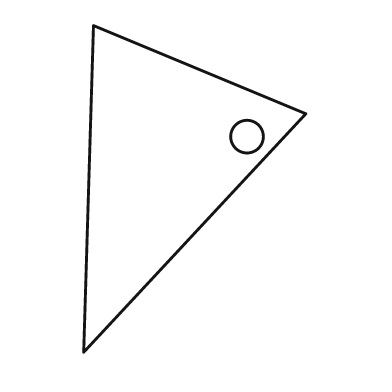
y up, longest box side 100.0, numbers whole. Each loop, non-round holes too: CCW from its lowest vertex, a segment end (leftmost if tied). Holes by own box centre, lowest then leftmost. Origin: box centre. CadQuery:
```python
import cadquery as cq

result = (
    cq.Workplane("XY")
    .moveTo(-34.0, -50.0)
    .lineTo(34.0, 23.0)
    .lineTo(-31.0, 50.0)
    .close()
    .moveTo(16.0, 16.0)
    .circle(5.0)
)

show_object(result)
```